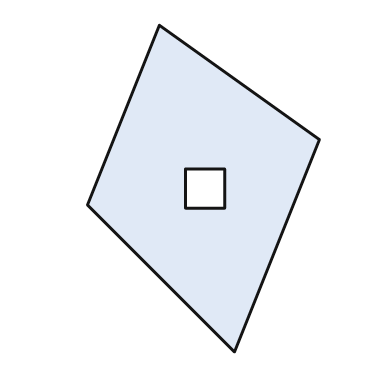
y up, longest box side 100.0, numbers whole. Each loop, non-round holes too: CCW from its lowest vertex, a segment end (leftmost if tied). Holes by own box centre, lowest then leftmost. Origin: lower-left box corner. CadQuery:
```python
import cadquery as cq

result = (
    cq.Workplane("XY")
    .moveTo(45.0, 0.0)
    .lineTo(71.0, 65.0)
    .lineTo(22.0, 100.0)
    .lineTo(0.0, 45.0)
    .close()
    .moveTo(30.0, 44.0)
    .lineTo(42.0, 44.0)
    .lineTo(42.0, 56.0)
    .lineTo(30.0, 56.0)
    .close()
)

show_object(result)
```